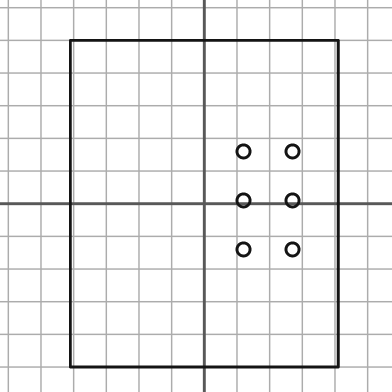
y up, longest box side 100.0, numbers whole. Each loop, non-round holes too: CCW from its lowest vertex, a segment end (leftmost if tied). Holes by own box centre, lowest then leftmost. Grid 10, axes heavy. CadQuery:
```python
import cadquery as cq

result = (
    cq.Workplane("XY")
    .moveTo(-41.0, -50.0)
    .lineTo(41.0, -50.0)
    .lineTo(41.0, 50.0)
    .lineTo(-41.0, 50.0)
    .close()
    .moveTo(12.0, -14.0)
    .circle(2.0)
    .moveTo(27.0, -14.0)
    .circle(2.0)
    .moveTo(12.0, 1.0)
    .circle(2.0)
    .moveTo(27.0, 1.0)
    .circle(2.0)
    .moveTo(12.0, 16.0)
    .circle(2.0)
    .moveTo(27.0, 16.0)
    .circle(2.0)
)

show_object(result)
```